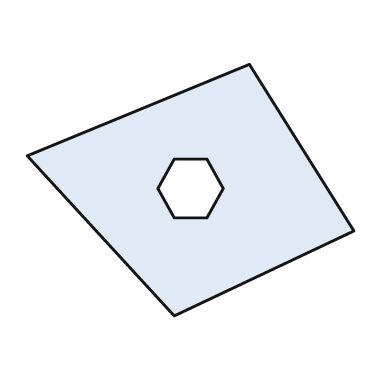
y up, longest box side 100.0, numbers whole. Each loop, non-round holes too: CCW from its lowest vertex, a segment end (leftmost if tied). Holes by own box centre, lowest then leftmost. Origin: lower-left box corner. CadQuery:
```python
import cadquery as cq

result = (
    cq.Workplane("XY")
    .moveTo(45.0, 0.0)
    .lineTo(100.0, 26.0)
    .lineTo(68.0, 77.0)
    .lineTo(0.0, 49.0)
    .close()
    .moveTo(45.0, 30.0)
    .lineTo(55.0, 30.0)
    .lineTo(60.0, 39.0)
    .lineTo(55.0, 48.0)
    .lineTo(45.0, 48.0)
    .lineTo(40.0, 39.0)
    .close()
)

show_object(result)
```